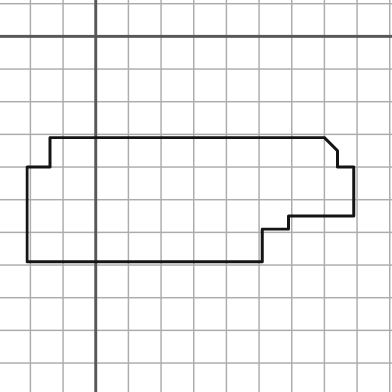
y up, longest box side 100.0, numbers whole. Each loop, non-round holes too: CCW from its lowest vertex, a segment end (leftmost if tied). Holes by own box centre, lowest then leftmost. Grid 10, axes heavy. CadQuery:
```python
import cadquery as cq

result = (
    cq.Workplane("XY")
    .moveTo(-21.0, -69.0)
    .lineTo(51.0, -69.0)
    .lineTo(51.0, -59.0)
    .lineTo(59.0, -59.0)
    .lineTo(59.0, -55.0)
    .lineTo(79.0, -55.0)
    .lineTo(79.0, -40.0)
    .lineTo(74.0, -40.0)
    .lineTo(74.0, -35.0)
    .lineTo(70.0, -31.0)
    .lineTo(-14.0, -31.0)
    .lineTo(-14.0, -40.0)
    .lineTo(-21.0, -40.0)
    .close()
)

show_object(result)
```